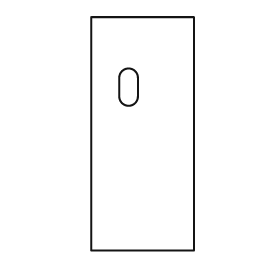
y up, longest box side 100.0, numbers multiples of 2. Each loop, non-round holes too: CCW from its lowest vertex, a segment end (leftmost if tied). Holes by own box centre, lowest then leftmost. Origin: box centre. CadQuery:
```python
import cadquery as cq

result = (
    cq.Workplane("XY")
    .moveTo(-22.0, -50.0)
    .lineTo(22.0, -50.0)
    .lineTo(22.0, 50.0)
    .lineTo(-22.0, 50.0)
    .close()
    .moveTo(-10.0, 16.0)
    .threePointArc((-6.0, 12.0), (-2.0, 16.0))
    .lineTo(-2.0, 24.0)
    .threePointArc((-6.0, 28.0), (-10.0, 24.0))
    .close()
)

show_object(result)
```